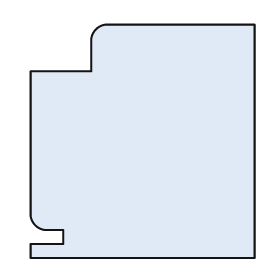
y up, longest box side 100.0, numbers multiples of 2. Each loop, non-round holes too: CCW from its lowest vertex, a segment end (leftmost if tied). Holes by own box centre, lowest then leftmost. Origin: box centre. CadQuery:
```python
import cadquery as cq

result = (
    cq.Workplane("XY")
    .moveTo(-48.0, -50.0)
    .lineTo(48.0, -50.0)
    .lineTo(48.0, 50.0)
    .lineTo(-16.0, 50.0)
    .threePointArc((-20.0, 48.0), (-22.0, 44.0))
    .lineTo(-22.0, 30.0)
    .lineTo(-48.0, 30.0)
    .lineTo(-48.0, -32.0)
    .threePointArc((-46.0, -36.0), (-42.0, -38.0))
    .lineTo(-34.0, -38.0)
    .lineTo(-34.0, -44.0)
    .lineTo(-48.0, -44.0)
    .close()
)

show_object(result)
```